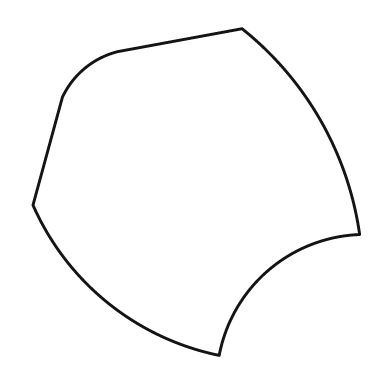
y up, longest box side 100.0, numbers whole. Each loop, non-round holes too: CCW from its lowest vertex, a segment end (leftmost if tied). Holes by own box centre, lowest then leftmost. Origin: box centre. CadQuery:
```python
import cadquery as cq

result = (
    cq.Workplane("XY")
    .moveTo(7.0, -50.0)
    .threePointArc((22.0, -24.0), (50.0, -13.0))
    .threePointArc((38.0, 22.0), (14.0, 50.0))
    .lineTo(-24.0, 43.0)
    .threePointArc((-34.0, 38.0), (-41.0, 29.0))
    .lineTo(-50.0, -4.0)
    .threePointArc((-27.0, -34.0), (7.0, -50.0))
    .close()
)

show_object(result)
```